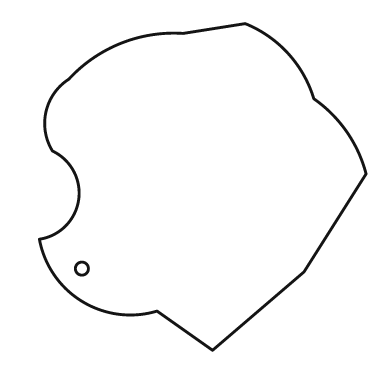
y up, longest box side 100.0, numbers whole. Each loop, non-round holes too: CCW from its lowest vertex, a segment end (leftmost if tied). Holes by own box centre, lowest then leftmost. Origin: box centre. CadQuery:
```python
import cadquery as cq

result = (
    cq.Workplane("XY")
    .moveTo(3.0, -50.0)
    .lineTo(31.0, -26.0)
    .lineTo(50.0, 4.0)
    .threePointArc((44.0, 17.0), (34.0, 27.0))
    .threePointArc((26.0, 41.0), (13.0, 50.0))
    .lineTo(-6.0, 47.0)
    .threePointArc((-25.0, 44.0), (-41.0, 33.0))
    .threePointArc((-48.0, 23.0), (-46.0, 11.0))
    .threePointArc((-38.0, -4.0), (-50.0, -16.0))
    .threePointArc((-37.0, -35.0), (-14.0, -38.0))
    .close()
    .moveTo(-37.0, -25.0)
    .circle(2.0)
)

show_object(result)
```